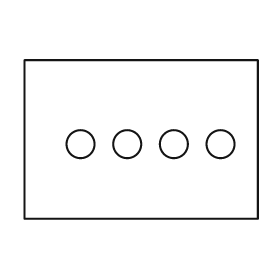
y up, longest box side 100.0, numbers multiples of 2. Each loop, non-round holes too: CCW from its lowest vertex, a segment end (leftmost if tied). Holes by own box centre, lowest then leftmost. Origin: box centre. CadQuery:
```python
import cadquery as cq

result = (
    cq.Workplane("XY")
    .moveTo(-50.0, -34.0)
    .lineTo(50.0, -34.0)
    .lineTo(50.0, 34.0)
    .lineTo(-50.0, 34.0)
    .close()
    .moveTo(-26.0, -2.0)
    .circle(6.0)
    .moveTo(-6.0, -2.0)
    .circle(6.0)
    .moveTo(14.0, -2.0)
    .circle(6.0)
    .moveTo(34.0, -2.0)
    .circle(6.0)
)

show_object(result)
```